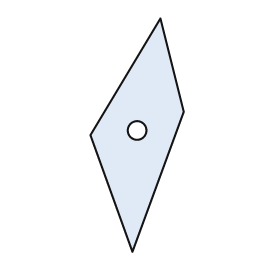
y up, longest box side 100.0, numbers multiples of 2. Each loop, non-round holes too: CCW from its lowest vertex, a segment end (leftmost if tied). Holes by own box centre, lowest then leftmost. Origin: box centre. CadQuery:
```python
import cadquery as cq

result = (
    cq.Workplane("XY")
    .moveTo(-2.0, -50.0)
    .lineTo(20.0, 10.0)
    .lineTo(10.0, 50.0)
    .lineTo(-20.0, 0.0)
    .close()
    .moveTo(0.0, 2.0)
    .circle(4.0)
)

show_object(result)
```